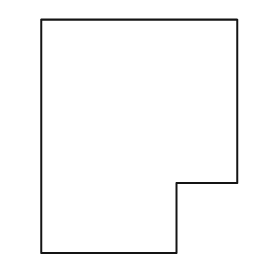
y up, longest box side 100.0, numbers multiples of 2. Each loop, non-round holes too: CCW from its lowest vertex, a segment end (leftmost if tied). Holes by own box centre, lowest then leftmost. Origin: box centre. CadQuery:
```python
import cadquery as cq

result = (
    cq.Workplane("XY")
    .moveTo(-42.0, -50.0)
    .lineTo(16.0, -50.0)
    .lineTo(16.0, -20.0)
    .lineTo(42.0, -20.0)
    .lineTo(42.0, 50.0)
    .lineTo(-42.0, 50.0)
    .close()
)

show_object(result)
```